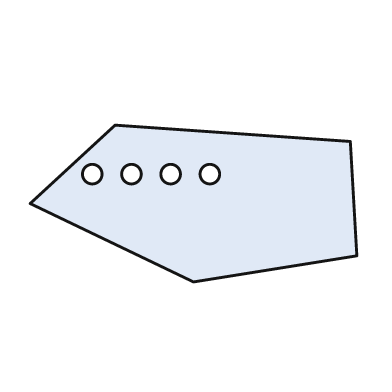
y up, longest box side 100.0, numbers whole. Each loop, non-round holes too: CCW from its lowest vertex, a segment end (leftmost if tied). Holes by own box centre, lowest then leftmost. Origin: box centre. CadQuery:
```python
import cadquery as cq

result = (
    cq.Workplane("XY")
    .moveTo(0.0, -24.0)
    .lineTo(50.0, -16.0)
    .lineTo(48.0, 19.0)
    .lineTo(-24.0, 24.0)
    .lineTo(-50.0, 0.0)
    .close()
    .moveTo(-31.0, 9.0)
    .circle(3.0)
    .moveTo(-19.0, 9.0)
    .circle(3.0)
    .moveTo(-7.0, 9.0)
    .circle(3.0)
    .moveTo(5.0, 9.0)
    .circle(3.0)
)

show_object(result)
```